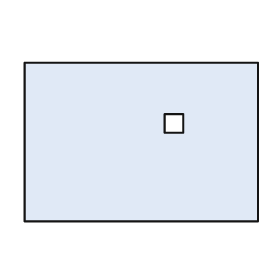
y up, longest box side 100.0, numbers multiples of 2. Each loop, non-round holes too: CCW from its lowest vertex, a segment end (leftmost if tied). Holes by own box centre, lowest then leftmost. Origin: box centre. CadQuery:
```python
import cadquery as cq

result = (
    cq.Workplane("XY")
    .moveTo(-50.0, -34.0)
    .lineTo(50.0, -34.0)
    .lineTo(50.0, 34.0)
    .lineTo(-50.0, 34.0)
    .close()
    .moveTo(10.0, 4.0)
    .lineTo(18.0, 4.0)
    .lineTo(18.0, 12.0)
    .lineTo(10.0, 12.0)
    .close()
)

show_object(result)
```